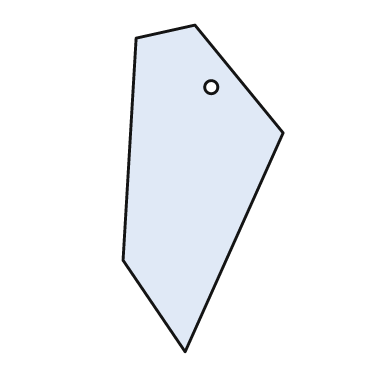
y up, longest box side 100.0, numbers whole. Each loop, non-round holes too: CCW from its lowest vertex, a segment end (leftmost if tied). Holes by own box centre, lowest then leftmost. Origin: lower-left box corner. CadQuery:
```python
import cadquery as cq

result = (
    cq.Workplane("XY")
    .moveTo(19.0, 0.0)
    .lineTo(49.0, 67.0)
    .lineTo(22.0, 100.0)
    .lineTo(4.0, 96.0)
    .lineTo(0.0, 28.0)
    .close()
    .moveTo(27.0, 81.0)
    .circle(2.0)
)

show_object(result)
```